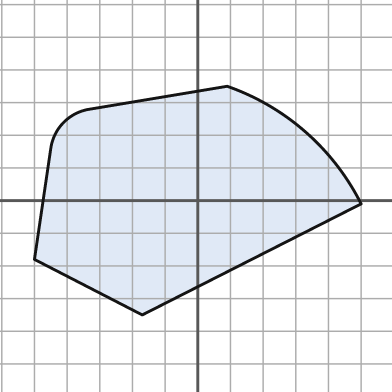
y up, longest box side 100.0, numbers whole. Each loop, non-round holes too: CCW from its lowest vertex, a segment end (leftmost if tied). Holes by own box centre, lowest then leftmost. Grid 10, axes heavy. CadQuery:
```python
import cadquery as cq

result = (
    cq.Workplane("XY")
    .moveTo(-17.0, -35.0)
    .lineTo(50.0, -1.0)
    .threePointArc((33.0, 21.0), (9.0, 35.0))
    .lineTo(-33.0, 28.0)
    .threePointArc((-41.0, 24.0), (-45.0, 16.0))
    .lineTo(-50.0, -18.0)
    .close()
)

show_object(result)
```